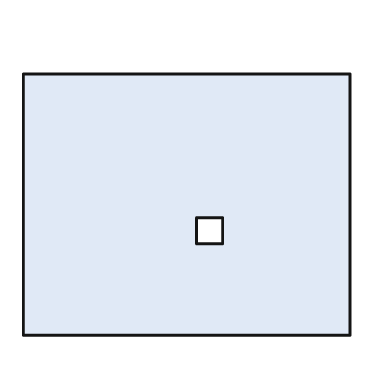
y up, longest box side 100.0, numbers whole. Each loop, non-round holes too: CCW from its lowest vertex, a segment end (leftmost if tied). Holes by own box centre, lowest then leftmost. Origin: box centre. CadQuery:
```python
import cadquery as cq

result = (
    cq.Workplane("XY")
    .moveTo(-50.0, -40.0)
    .lineTo(50.0, -40.0)
    .lineTo(50.0, 40.0)
    .lineTo(-50.0, 40.0)
    .close()
    .moveTo(3.0, -12.0)
    .lineTo(11.0, -12.0)
    .lineTo(11.0, -4.0)
    .lineTo(3.0, -4.0)
    .close()
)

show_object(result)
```